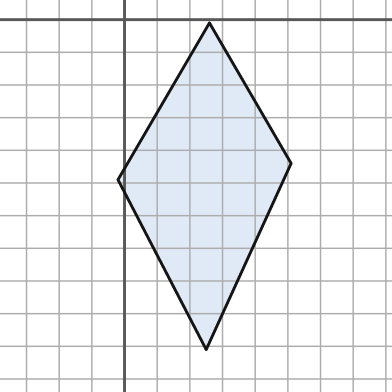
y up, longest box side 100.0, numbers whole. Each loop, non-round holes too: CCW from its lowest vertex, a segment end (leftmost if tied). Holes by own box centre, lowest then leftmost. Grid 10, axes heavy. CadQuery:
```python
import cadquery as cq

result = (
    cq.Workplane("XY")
    .moveTo(25.0, -101.0)
    .lineTo(51.0, -44.0)
    .lineTo(26.0, -1.0)
    .lineTo(-2.0, -49.0)
    .close()
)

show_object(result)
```